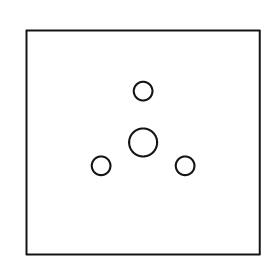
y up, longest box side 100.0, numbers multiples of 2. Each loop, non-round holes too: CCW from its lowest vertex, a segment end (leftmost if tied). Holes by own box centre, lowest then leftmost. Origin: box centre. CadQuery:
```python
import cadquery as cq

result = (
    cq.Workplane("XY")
    .moveTo(-50.0, -48.0)
    .lineTo(50.0, -48.0)
    .lineTo(50.0, 48.0)
    .lineTo(-50.0, 48.0)
    .close()
    .moveTo(-18.0, -10.0)
    .circle(4.0)
    .moveTo(18.0, -10.0)
    .circle(4.0)
    .moveTo(0.0, 0.0)
    .circle(6.0)
    .moveTo(0.0, 22.0)
    .circle(4.0)
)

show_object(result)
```